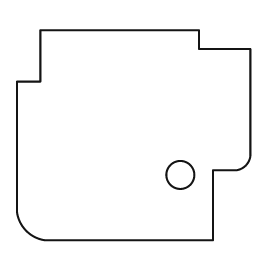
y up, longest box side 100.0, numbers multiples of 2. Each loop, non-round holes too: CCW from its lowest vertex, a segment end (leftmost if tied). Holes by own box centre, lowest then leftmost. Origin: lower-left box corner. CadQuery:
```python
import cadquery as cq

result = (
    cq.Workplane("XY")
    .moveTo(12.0, 0.0)
    .lineTo(84.0, 0.0)
    .lineTo(84.0, 30.0)
    .lineTo(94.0, 30.0)
    .threePointArc((98.0, 32.0), (100.0, 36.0))
    .lineTo(100.0, 82.0)
    .lineTo(78.0, 82.0)
    .lineTo(78.0, 90.0)
    .lineTo(10.0, 90.0)
    .lineTo(10.0, 68.0)
    .lineTo(0.0, 68.0)
    .lineTo(0.0, 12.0)
    .threePointArc((4.0, 4.0), (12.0, 0.0))
    .close()
    .moveTo(70.0, 28.0)
    .circle(6.0)
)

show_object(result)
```